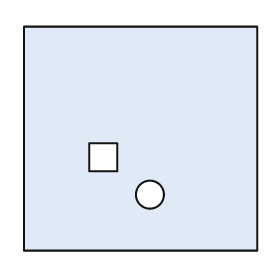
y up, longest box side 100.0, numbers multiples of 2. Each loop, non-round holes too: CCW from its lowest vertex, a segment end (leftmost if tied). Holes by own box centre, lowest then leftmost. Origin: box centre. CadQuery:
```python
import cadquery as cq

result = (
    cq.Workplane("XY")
    .moveTo(-50.0, -48.0)
    .lineTo(50.0, -48.0)
    .lineTo(50.0, 48.0)
    .lineTo(-50.0, 48.0)
    .close()
    .moveTo(4.0, -24.0)
    .circle(6.0)
    .moveTo(-22.0, -14.0)
    .lineTo(-10.0, -14.0)
    .lineTo(-10.0, -2.0)
    .lineTo(-22.0, -2.0)
    .close()
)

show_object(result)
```